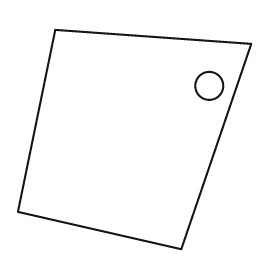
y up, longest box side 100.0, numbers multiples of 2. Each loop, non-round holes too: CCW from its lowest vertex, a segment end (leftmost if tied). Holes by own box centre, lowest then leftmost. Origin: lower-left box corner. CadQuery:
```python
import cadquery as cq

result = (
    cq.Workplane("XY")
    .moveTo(70.0, 0.0)
    .lineTo(100.0, 88.0)
    .lineTo(16.0, 94.0)
    .lineTo(0.0, 16.0)
    .close()
    .moveTo(82.0, 70.0)
    .circle(6.0)
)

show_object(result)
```